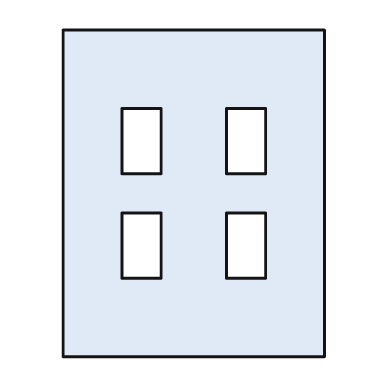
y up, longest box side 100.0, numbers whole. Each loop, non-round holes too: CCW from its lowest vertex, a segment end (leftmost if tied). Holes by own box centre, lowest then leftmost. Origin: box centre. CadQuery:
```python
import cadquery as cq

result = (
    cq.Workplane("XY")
    .moveTo(-40.0, -50.0)
    .lineTo(40.0, -50.0)
    .lineTo(40.0, 50.0)
    .lineTo(-40.0, 50.0)
    .close()
    .moveTo(-22.0, -26.0)
    .lineTo(-10.0, -26.0)
    .lineTo(-10.0, -6.0)
    .lineTo(-22.0, -6.0)
    .close()
    .moveTo(10.0, -26.0)
    .lineTo(22.0, -26.0)
    .lineTo(22.0, -6.0)
    .lineTo(10.0, -6.0)
    .close()
    .moveTo(-22.0, 6.0)
    .lineTo(-10.0, 6.0)
    .lineTo(-10.0, 26.0)
    .lineTo(-22.0, 26.0)
    .close()
    .moveTo(10.0, 6.0)
    .lineTo(22.0, 6.0)
    .lineTo(22.0, 26.0)
    .lineTo(10.0, 26.0)
    .close()
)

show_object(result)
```